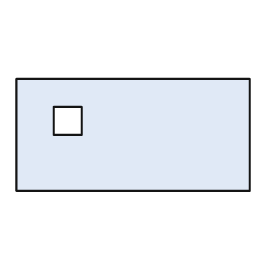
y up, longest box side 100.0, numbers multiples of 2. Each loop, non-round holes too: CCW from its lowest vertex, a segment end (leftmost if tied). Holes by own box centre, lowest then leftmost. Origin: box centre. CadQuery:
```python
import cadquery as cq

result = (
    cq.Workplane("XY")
    .moveTo(-50.0, -24.0)
    .lineTo(50.0, -24.0)
    .lineTo(50.0, 24.0)
    .lineTo(-50.0, 24.0)
    .close()
    .moveTo(-34.0, 0.0)
    .lineTo(-22.0, 0.0)
    .lineTo(-22.0, 12.0)
    .lineTo(-34.0, 12.0)
    .close()
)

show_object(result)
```